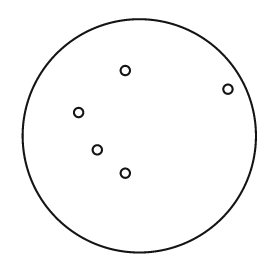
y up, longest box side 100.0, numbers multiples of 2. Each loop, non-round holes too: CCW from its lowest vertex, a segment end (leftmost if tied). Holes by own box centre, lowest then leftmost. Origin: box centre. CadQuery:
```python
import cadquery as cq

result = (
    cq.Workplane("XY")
    .moveTo(0.0, 0.0)
    .circle(50.0)
    .moveTo(-6.0, -16.0)
    .circle(2.0)
    .moveTo(-18.0, -6.0)
    .circle(2.0)
    .moveTo(-26.0, 10.0)
    .circle(2.0)
    .moveTo(38.0, 20.0)
    .circle(2.0)
    .moveTo(-6.0, 28.0)
    .circle(2.0)
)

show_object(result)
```